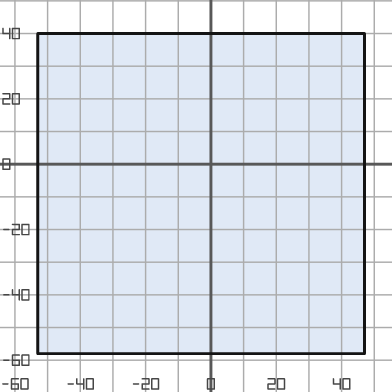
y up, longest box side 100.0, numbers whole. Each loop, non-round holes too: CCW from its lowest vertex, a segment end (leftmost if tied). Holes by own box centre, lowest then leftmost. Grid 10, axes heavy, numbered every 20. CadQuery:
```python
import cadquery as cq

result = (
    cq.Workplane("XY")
    .moveTo(-53.0, -58.0)
    .lineTo(47.0, -58.0)
    .lineTo(47.0, 40.0)
    .lineTo(-53.0, 40.0)
    .close()
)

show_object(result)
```